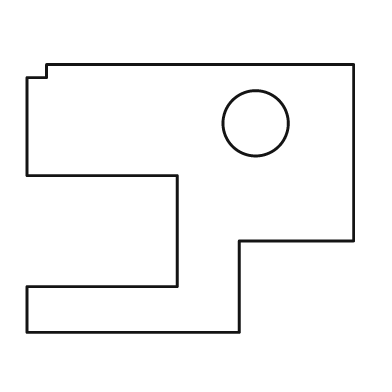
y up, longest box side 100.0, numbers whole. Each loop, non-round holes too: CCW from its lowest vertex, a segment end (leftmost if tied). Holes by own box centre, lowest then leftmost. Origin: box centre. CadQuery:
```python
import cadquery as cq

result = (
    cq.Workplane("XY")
    .moveTo(-50.0, -41.0)
    .lineTo(15.0, -41.0)
    .lineTo(15.0, -13.0)
    .lineTo(50.0, -13.0)
    .lineTo(50.0, 41.0)
    .lineTo(-44.0, 41.0)
    .lineTo(-44.0, 37.0)
    .lineTo(-50.0, 37.0)
    .lineTo(-50.0, 7.0)
    .lineTo(-4.0, 7.0)
    .lineTo(-4.0, -27.0)
    .lineTo(-50.0, -27.0)
    .close()
    .moveTo(20.0, 23.0)
    .circle(10.0)
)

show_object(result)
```